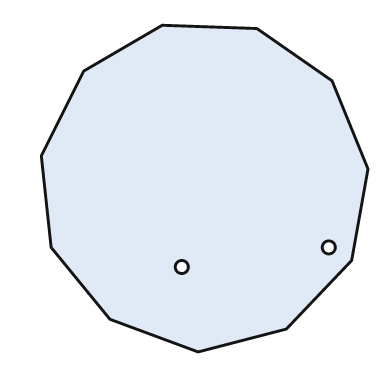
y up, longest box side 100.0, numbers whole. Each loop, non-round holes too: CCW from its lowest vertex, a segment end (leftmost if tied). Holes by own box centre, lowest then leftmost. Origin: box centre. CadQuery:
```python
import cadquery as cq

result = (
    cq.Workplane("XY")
    .moveTo(-2.0, -50.0)
    .lineTo(25.0, -43.0)
    .lineTo(45.0, -22.0)
    .lineTo(50.0, 6.0)
    .lineTo(39.0, 33.0)
    .lineTo(16.0, 49.0)
    .lineTo(-13.0, 50.0)
    .lineTo(-37.0, 36.0)
    .lineTo(-50.0, 10.0)
    .lineTo(-47.0, -18.0)
    .lineTo(-29.0, -40.0)
    .close()
    .moveTo(-7.0, -24.0)
    .circle(2.0)
    .moveTo(38.0, -18.0)
    .circle(2.0)
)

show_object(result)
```